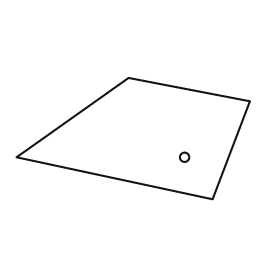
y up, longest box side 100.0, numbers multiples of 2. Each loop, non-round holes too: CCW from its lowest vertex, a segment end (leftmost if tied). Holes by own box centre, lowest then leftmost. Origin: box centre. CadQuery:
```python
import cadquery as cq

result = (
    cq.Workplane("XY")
    .moveTo(34.0, -26.0)
    .lineTo(50.0, 16.0)
    .lineTo(-2.0, 26.0)
    .lineTo(-50.0, -8.0)
    .close()
    .moveTo(22.0, -8.0)
    .circle(2.0)
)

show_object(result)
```